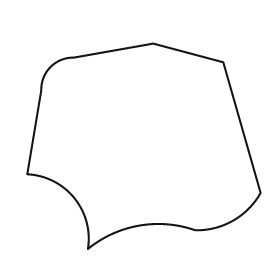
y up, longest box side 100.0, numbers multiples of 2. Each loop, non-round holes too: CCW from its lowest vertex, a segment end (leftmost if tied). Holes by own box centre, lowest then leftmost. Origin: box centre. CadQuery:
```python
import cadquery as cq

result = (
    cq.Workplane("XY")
    .moveTo(-24.0, -44.0)
    .threePointArc((-2.0, -34.0), (22.0, -36.0))
    .threePointArc((38.0, -32.0), (50.0, -20.0))
    .lineTo(34.0, 36.0)
    .lineTo(4.0, 44.0)
    .lineTo(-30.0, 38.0)
    .threePointArc((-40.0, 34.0), (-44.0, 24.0))
    .lineTo(-50.0, -12.0)
    .threePointArc((-30.0, -22.0), (-24.0, -44.0))
    .close()
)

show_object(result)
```